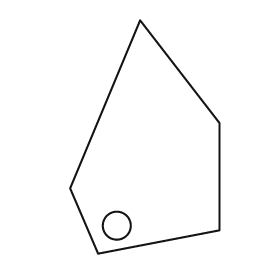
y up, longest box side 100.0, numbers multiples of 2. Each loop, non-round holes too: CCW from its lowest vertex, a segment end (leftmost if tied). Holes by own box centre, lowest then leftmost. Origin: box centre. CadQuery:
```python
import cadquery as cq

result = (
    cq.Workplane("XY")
    .moveTo(-20.0, -50.0)
    .lineTo(32.0, -40.0)
    .lineTo(32.0, 6.0)
    .lineTo(-2.0, 50.0)
    .lineTo(-32.0, -22.0)
    .close()
    .moveTo(-12.0, -38.0)
    .circle(6.0)
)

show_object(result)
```